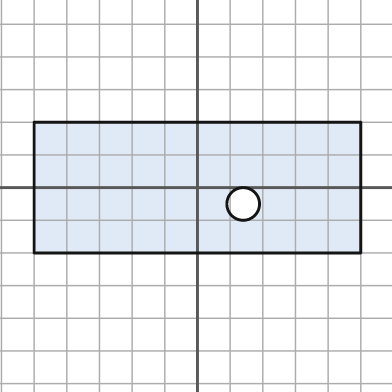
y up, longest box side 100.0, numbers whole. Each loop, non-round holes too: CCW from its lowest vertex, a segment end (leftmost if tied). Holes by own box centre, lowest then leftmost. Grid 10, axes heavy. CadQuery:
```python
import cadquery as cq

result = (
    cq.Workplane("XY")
    .moveTo(-50.0, -20.0)
    .lineTo(50.0, -20.0)
    .lineTo(50.0, 20.0)
    .lineTo(-50.0, 20.0)
    .close()
    .moveTo(14.0, -5.0)
    .circle(5.0)
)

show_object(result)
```